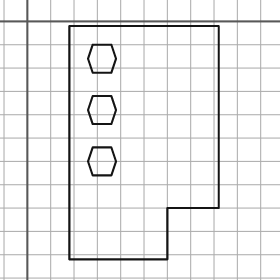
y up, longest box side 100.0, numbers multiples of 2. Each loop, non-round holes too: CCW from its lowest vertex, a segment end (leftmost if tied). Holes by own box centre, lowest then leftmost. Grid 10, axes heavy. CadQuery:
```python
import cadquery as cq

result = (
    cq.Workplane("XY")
    .moveTo(18.0, -102.0)
    .lineTo(60.0, -102.0)
    .lineTo(60.0, -80.0)
    .lineTo(82.0, -80.0)
    .lineTo(82.0, -2.0)
    .lineTo(18.0, -2.0)
    .close()
    .moveTo(28.0, -66.0)
    .lineTo(36.0, -66.0)
    .lineTo(38.0, -60.0)
    .lineTo(36.0, -54.0)
    .lineTo(28.0, -54.0)
    .lineTo(26.0, -60.0)
    .close()
    .moveTo(28.0, -44.0)
    .lineTo(36.0, -44.0)
    .lineTo(38.0, -38.0)
    .lineTo(36.0, -32.0)
    .lineTo(28.0, -32.0)
    .lineTo(26.0, -38.0)
    .close()
    .moveTo(28.0, -22.0)
    .lineTo(36.0, -22.0)
    .lineTo(38.0, -16.0)
    .lineTo(36.0, -10.0)
    .lineTo(28.0, -10.0)
    .lineTo(26.0, -16.0)
    .close()
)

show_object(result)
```